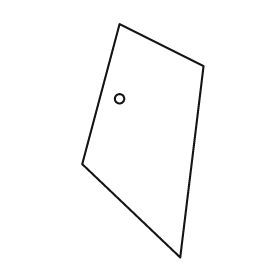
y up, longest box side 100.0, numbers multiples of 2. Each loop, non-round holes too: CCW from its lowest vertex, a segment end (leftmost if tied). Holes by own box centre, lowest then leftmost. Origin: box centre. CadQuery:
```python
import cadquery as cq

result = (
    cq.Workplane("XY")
    .moveTo(16.0, -50.0)
    .lineTo(26.0, 32.0)
    .lineTo(-10.0, 50.0)
    .lineTo(-26.0, -10.0)
    .close()
    .moveTo(-10.0, 18.0)
    .circle(2.0)
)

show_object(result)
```